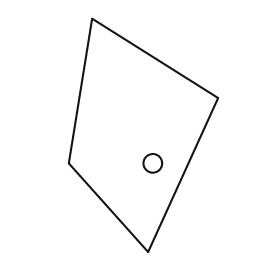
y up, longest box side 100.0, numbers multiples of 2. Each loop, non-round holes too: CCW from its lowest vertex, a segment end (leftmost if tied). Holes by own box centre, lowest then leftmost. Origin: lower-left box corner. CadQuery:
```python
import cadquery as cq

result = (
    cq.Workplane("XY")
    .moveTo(34.0, 0.0)
    .lineTo(64.0, 66.0)
    .lineTo(10.0, 100.0)
    .lineTo(0.0, 38.0)
    .close()
    .moveTo(36.0, 38.0)
    .circle(4.0)
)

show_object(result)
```